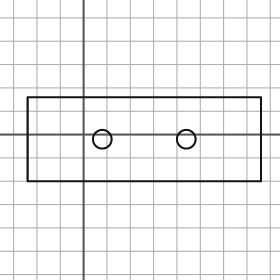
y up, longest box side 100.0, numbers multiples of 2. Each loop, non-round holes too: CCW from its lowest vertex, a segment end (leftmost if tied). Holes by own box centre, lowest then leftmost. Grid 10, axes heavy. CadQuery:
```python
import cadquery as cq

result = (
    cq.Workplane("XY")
    .moveTo(-24.0, -20.0)
    .lineTo(76.0, -20.0)
    .lineTo(76.0, 16.0)
    .lineTo(-24.0, 16.0)
    .close()
    .moveTo(8.0, -2.0)
    .circle(4.0)
    .moveTo(44.0, -2.0)
    .circle(4.0)
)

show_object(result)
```